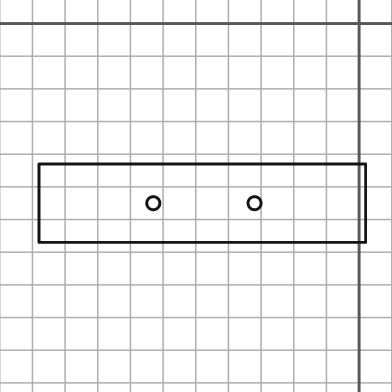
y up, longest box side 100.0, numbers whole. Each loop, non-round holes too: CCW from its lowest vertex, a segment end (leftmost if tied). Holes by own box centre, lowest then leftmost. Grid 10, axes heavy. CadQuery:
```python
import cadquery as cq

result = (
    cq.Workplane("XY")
    .moveTo(-98.0, -67.0)
    .lineTo(2.0, -67.0)
    .lineTo(2.0, -43.0)
    .lineTo(-98.0, -43.0)
    .close()
    .moveTo(-63.0, -55.0)
    .circle(2.0)
    .moveTo(-32.0, -55.0)
    .circle(2.0)
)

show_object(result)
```